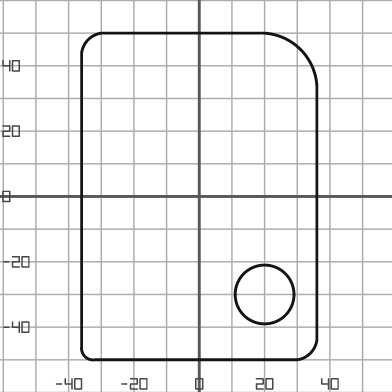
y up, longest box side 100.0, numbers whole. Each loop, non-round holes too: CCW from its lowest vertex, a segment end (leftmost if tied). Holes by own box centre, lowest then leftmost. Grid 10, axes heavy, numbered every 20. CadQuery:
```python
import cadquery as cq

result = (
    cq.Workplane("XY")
    .moveTo(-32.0, -50.0)
    .lineTo(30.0, -50.0)
    .threePointArc((34.0, -48.0), (36.0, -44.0))
    .lineTo(36.0, 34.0)
    .threePointArc((31.0, 45.0), (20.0, 50.0))
    .lineTo(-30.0, 50.0)
    .threePointArc((-34.0, 48.0), (-36.0, 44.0))
    .lineTo(-36.0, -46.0)
    .threePointArc((-35.0, -49.0), (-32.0, -50.0))
    .close()
    .moveTo(20.0, -30.0)
    .circle(9.0)
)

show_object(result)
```